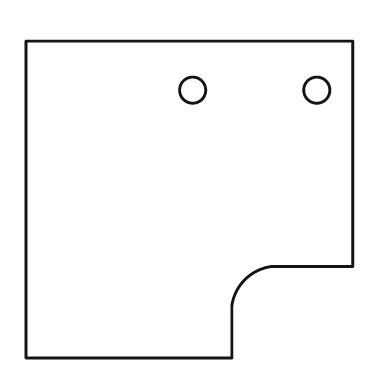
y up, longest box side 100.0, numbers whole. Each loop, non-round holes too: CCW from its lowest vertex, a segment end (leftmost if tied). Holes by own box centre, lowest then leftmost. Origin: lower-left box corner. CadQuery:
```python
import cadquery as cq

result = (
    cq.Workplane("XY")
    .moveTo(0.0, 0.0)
    .lineTo(63.0, 0.0)
    .lineTo(63.0, 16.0)
    .threePointArc((67.0, 24.0), (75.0, 28.0))
    .lineTo(100.0, 28.0)
    .lineTo(100.0, 97.0)
    .lineTo(0.0, 97.0)
    .close()
    .moveTo(51.0, 82.0)
    .circle(4.0)
    .moveTo(89.0, 82.0)
    .circle(4.0)
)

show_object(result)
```